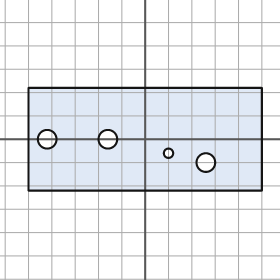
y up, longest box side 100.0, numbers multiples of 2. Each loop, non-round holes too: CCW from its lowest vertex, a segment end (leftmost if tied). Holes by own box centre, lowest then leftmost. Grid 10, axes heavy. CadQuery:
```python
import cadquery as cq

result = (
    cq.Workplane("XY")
    .moveTo(-50.0, -22.0)
    .lineTo(50.0, -22.0)
    .lineTo(50.0, 22.0)
    .lineTo(-50.0, 22.0)
    .close()
    .moveTo(26.0, -10.0)
    .circle(4.0)
    .moveTo(10.0, -6.0)
    .circle(2.0)
    .moveTo(-42.0, 0.0)
    .circle(4.0)
    .moveTo(-16.0, 0.0)
    .circle(4.0)
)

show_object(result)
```